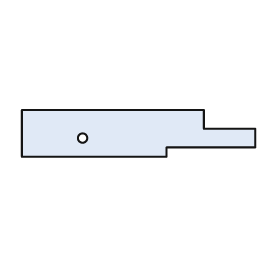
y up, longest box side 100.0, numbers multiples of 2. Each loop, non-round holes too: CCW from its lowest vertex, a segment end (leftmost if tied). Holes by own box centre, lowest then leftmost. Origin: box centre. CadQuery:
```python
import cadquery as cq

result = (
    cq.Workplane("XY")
    .moveTo(-50.0, -10.0)
    .lineTo(12.0, -10.0)
    .lineTo(12.0, -6.0)
    .lineTo(50.0, -6.0)
    .lineTo(50.0, 2.0)
    .lineTo(28.0, 2.0)
    .lineTo(28.0, 10.0)
    .lineTo(-50.0, 10.0)
    .close()
    .moveTo(-24.0, -2.0)
    .circle(2.0)
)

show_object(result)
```